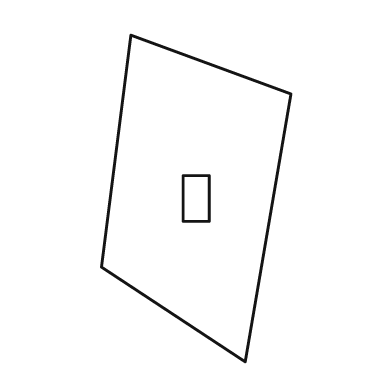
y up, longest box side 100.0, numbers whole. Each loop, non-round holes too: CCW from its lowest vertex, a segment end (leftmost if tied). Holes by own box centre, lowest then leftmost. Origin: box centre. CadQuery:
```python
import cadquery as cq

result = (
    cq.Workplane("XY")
    .moveTo(15.0, -50.0)
    .lineTo(29.0, 32.0)
    .lineTo(-20.0, 50.0)
    .lineTo(-29.0, -21.0)
    .close()
    .moveTo(-4.0, -7.0)
    .lineTo(4.0, -7.0)
    .lineTo(4.0, 7.0)
    .lineTo(-4.0, 7.0)
    .close()
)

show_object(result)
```